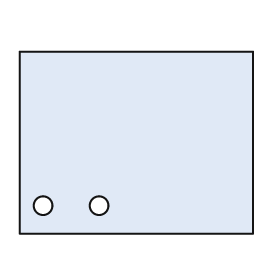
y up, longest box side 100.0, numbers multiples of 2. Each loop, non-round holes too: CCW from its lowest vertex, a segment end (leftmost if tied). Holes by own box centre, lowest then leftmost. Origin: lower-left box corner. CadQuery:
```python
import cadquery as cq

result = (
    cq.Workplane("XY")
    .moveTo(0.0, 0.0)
    .lineTo(100.0, 0.0)
    .lineTo(100.0, 78.0)
    .lineTo(0.0, 78.0)
    .close()
    .moveTo(10.0, 12.0)
    .circle(4.0)
    .moveTo(34.0, 12.0)
    .circle(4.0)
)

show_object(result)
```